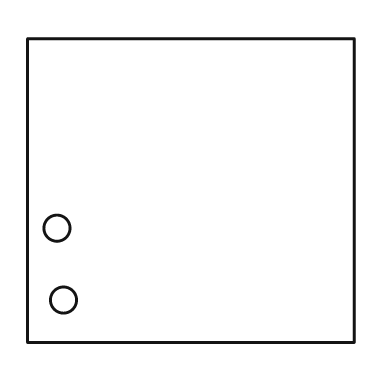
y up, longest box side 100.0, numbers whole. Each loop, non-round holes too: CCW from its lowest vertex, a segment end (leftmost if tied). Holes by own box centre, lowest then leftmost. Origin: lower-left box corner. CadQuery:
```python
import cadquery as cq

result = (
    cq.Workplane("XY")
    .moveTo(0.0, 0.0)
    .lineTo(100.0, 0.0)
    .lineTo(100.0, 93.0)
    .lineTo(0.0, 93.0)
    .close()
    .moveTo(11.0, 13.0)
    .circle(4.0)
    .moveTo(9.0, 35.0)
    .circle(4.0)
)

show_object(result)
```